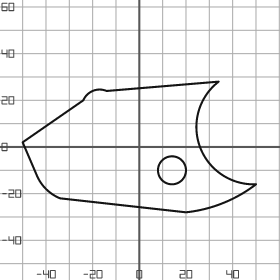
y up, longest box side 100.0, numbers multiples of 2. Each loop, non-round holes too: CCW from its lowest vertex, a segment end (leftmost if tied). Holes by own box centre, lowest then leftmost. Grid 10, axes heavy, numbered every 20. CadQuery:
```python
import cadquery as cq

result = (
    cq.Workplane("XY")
    .moveTo(20.0, -28.0)
    .threePointArc((36.0, -24.0), (50.0, -16.0))
    .threePointArc((26.0, 0.0), (34.0, 28.0))
    .lineTo(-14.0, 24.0)
    .threePointArc((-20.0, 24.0), (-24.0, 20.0))
    .lineTo(-50.0, 2.0)
    .lineTo(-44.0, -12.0)
    .threePointArc((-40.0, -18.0), (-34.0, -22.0))
    .close()
    .moveTo(14.0, -10.0)
    .circle(6.0)
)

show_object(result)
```